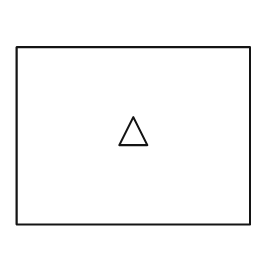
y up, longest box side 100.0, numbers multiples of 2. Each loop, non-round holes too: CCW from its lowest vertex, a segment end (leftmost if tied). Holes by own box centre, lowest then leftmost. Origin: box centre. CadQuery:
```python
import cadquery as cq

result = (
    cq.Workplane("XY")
    .moveTo(-50.0, -38.0)
    .lineTo(50.0, -38.0)
    .lineTo(50.0, 38.0)
    .lineTo(-50.0, 38.0)
    .close()
    .moveTo(-6.0, -4.0)
    .lineTo(6.0, -4.0)
    .lineTo(0.0, 8.0)
    .close()
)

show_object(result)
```